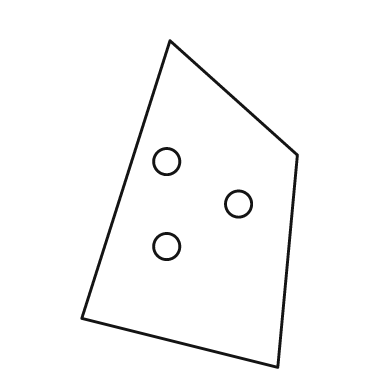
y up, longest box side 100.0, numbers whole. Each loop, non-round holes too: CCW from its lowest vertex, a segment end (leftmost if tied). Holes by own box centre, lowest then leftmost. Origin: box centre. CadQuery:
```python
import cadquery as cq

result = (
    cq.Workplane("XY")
    .moveTo(27.0, -50.0)
    .lineTo(33.0, 15.0)
    .lineTo(-6.0, 50.0)
    .lineTo(-33.0, -35.0)
    .close()
    .moveTo(-7.0, -13.0)
    .circle(4.0)
    .moveTo(15.0, 0.0)
    .circle(4.0)
    .moveTo(-7.0, 13.0)
    .circle(4.0)
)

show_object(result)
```